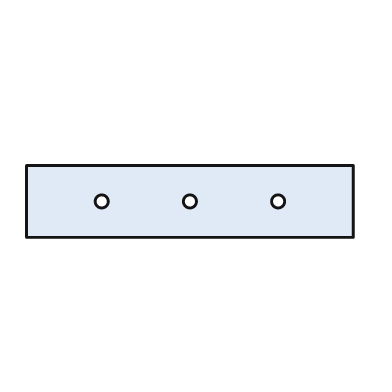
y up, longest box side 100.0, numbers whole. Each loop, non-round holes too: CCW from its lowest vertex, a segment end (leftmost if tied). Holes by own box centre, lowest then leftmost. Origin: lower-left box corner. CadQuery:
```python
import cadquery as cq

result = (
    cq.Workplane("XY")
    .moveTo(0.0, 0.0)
    .lineTo(100.0, 0.0)
    .lineTo(100.0, 22.0)
    .lineTo(0.0, 22.0)
    .close()
    .moveTo(23.0, 11.0)
    .circle(2.0)
    .moveTo(50.0, 11.0)
    .circle(2.0)
    .moveTo(77.0, 11.0)
    .circle(2.0)
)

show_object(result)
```